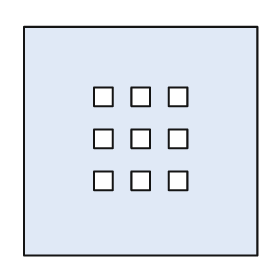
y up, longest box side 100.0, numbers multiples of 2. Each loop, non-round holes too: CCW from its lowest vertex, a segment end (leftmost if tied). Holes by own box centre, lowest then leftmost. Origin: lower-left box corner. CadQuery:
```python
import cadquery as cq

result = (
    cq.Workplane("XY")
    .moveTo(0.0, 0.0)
    .lineTo(100.0, 0.0)
    .lineTo(100.0, 98.0)
    .lineTo(0.0, 98.0)
    .close()
    .moveTo(30.0, 28.0)
    .lineTo(38.0, 28.0)
    .lineTo(38.0, 36.0)
    .lineTo(30.0, 36.0)
    .close()
    .moveTo(46.0, 28.0)
    .lineTo(54.0, 28.0)
    .lineTo(54.0, 36.0)
    .lineTo(46.0, 36.0)
    .close()
    .moveTo(62.0, 28.0)
    .lineTo(70.0, 28.0)
    .lineTo(70.0, 36.0)
    .lineTo(62.0, 36.0)
    .close()
    .moveTo(30.0, 46.0)
    .lineTo(38.0, 46.0)
    .lineTo(38.0, 54.0)
    .lineTo(30.0, 54.0)
    .close()
    .moveTo(46.0, 46.0)
    .lineTo(54.0, 46.0)
    .lineTo(54.0, 54.0)
    .lineTo(46.0, 54.0)
    .close()
    .moveTo(62.0, 46.0)
    .lineTo(70.0, 46.0)
    .lineTo(70.0, 54.0)
    .lineTo(62.0, 54.0)
    .close()
    .moveTo(30.0, 64.0)
    .lineTo(38.0, 64.0)
    .lineTo(38.0, 72.0)
    .lineTo(30.0, 72.0)
    .close()
    .moveTo(46.0, 64.0)
    .lineTo(54.0, 64.0)
    .lineTo(54.0, 72.0)
    .lineTo(46.0, 72.0)
    .close()
    .moveTo(62.0, 64.0)
    .lineTo(70.0, 64.0)
    .lineTo(70.0, 72.0)
    .lineTo(62.0, 72.0)
    .close()
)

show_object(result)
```